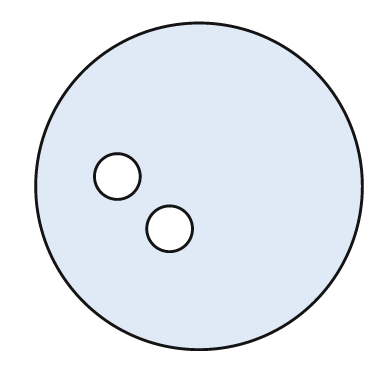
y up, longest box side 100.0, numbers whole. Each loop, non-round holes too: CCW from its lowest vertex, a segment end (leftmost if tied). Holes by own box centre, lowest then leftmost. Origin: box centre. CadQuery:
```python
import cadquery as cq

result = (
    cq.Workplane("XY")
    .moveTo(0.0, 0.0)
    .circle(50.0)
    .moveTo(-9.0, -13.0)
    .circle(7.0)
    .moveTo(-25.0, 3.0)
    .circle(7.0)
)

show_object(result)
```